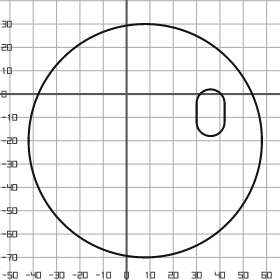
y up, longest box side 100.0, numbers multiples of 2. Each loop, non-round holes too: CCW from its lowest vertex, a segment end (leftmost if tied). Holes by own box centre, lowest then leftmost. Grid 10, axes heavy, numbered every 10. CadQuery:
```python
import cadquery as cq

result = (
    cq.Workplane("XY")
    .moveTo(8.0, -20.0)
    .circle(50.0)
    .moveTo(30.0, -12.0)
    .threePointArc((36.0, -18.0), (42.0, -12.0))
    .lineTo(42.0, -4.0)
    .threePointArc((36.0, 2.0), (30.0, -4.0))
    .close()
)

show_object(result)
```